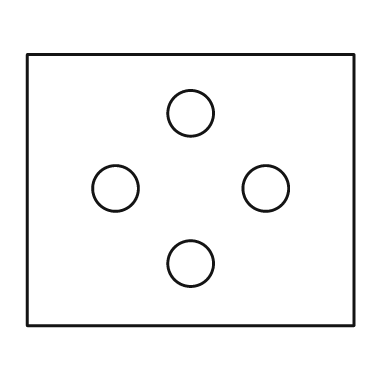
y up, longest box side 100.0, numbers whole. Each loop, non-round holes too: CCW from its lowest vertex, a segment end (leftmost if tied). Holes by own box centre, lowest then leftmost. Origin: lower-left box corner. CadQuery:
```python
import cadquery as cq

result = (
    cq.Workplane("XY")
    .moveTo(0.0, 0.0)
    .lineTo(100.0, 0.0)
    .lineTo(100.0, 83.0)
    .lineTo(0.0, 83.0)
    .close()
    .moveTo(50.0, 19.0)
    .circle(7.0)
    .moveTo(27.0, 42.0)
    .circle(7.0)
    .moveTo(73.0, 42.0)
    .circle(7.0)
    .moveTo(50.0, 65.0)
    .circle(7.0)
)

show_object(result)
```